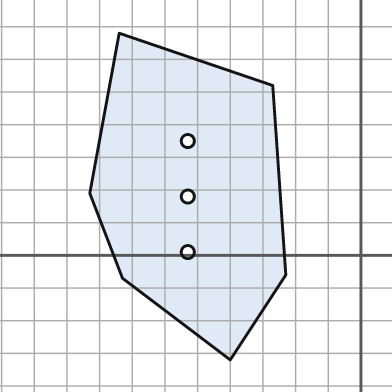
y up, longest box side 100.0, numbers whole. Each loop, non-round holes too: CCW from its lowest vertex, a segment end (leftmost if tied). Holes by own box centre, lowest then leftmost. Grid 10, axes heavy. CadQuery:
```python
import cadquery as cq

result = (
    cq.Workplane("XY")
    .moveTo(-40.0, -32.0)
    .lineTo(-23.0, -6.0)
    .lineTo(-27.0, 52.0)
    .lineTo(-74.0, 68.0)
    .lineTo(-83.0, 19.0)
    .lineTo(-73.0, -7.0)
    .close()
    .moveTo(-53.0, 1.0)
    .circle(2.0)
    .moveTo(-53.0, 18.0)
    .circle(2.0)
    .moveTo(-53.0, 35.0)
    .circle(2.0)
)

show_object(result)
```